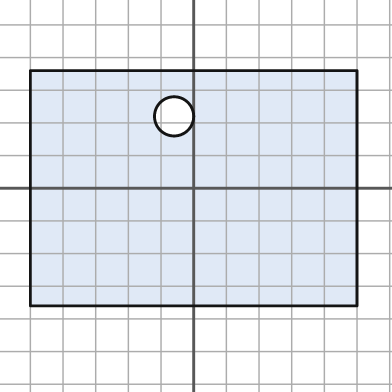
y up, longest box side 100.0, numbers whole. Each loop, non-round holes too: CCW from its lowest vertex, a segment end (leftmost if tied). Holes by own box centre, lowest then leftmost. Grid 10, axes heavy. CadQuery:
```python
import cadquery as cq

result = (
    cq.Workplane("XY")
    .moveTo(-50.0, -36.0)
    .lineTo(50.0, -36.0)
    .lineTo(50.0, 36.0)
    .lineTo(-50.0, 36.0)
    .close()
    .moveTo(-6.0, 22.0)
    .circle(6.0)
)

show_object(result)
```